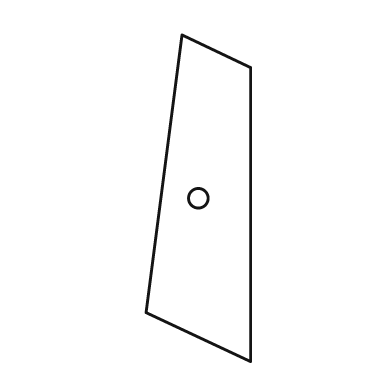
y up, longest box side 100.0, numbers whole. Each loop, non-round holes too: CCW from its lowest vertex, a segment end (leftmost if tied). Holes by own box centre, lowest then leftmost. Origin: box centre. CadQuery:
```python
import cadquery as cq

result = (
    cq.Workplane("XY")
    .moveTo(16.0, -50.0)
    .lineTo(16.0, 40.0)
    .lineTo(-5.0, 50.0)
    .lineTo(-16.0, -35.0)
    .close()
    .moveTo(0.0, 0.0)
    .circle(3.0)
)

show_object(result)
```